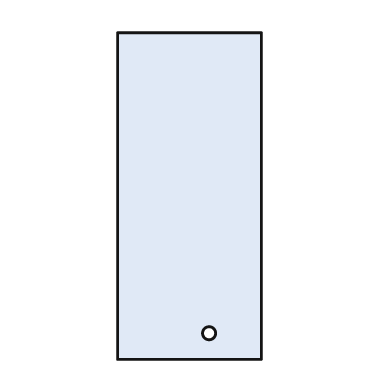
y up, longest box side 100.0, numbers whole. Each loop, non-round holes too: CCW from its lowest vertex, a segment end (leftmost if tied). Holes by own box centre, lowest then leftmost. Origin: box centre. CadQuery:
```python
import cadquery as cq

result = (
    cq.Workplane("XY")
    .moveTo(-22.0, -50.0)
    .lineTo(22.0, -50.0)
    .lineTo(22.0, 50.0)
    .lineTo(-22.0, 50.0)
    .close()
    .moveTo(6.0, -42.0)
    .circle(2.0)
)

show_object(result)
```